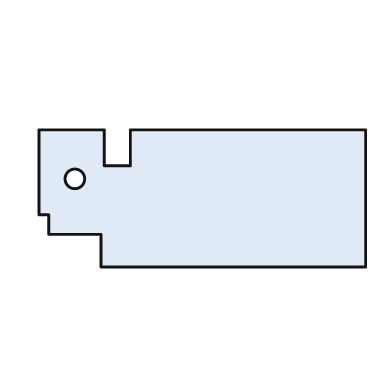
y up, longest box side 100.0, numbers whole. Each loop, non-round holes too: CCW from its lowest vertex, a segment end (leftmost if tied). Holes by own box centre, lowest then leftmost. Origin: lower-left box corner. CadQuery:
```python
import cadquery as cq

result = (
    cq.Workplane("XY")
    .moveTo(19.0, 0.0)
    .lineTo(100.0, 0.0)
    .lineTo(100.0, 42.0)
    .lineTo(28.0, 42.0)
    .lineTo(28.0, 31.0)
    .lineTo(20.0, 31.0)
    .lineTo(20.0, 42.0)
    .lineTo(0.0, 42.0)
    .lineTo(0.0, 16.0)
    .lineTo(3.0, 16.0)
    .lineTo(3.0, 10.0)
    .lineTo(19.0, 10.0)
    .close()
    .moveTo(11.0, 27.0)
    .circle(3.0)
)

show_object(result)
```